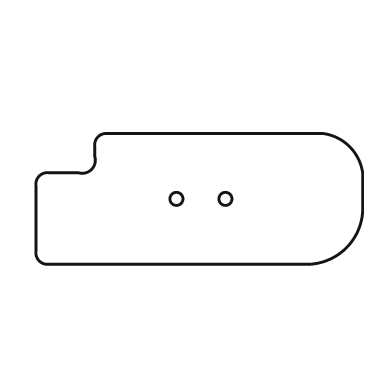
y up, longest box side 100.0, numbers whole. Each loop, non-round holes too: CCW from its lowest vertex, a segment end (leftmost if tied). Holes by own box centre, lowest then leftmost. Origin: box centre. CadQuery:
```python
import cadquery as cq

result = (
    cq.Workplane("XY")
    .moveTo(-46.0, -20.0)
    .lineTo(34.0, -20.0)
    .threePointArc((45.0, -15.0), (50.0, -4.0))
    .lineTo(50.0, 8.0)
    .threePointArc((46.0, 16.0), (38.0, 20.0))
    .lineTo(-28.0, 20.0)
    .threePointArc((-31.0, 19.0), (-32.0, 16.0))
    .lineTo(-32.0, 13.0)
    .threePointArc((-33.0, 9.0), (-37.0, 8.0))
    .lineTo(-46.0, 8.0)
    .threePointArc((-49.0, 7.0), (-50.0, 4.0))
    .lineTo(-50.0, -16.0)
    .threePointArc((-49.0, -19.0), (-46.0, -20.0))
    .close()
    .moveTo(-7.0, 0.0)
    .circle(2.0)
    .moveTo(8.0, 0.0)
    .circle(2.0)
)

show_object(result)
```